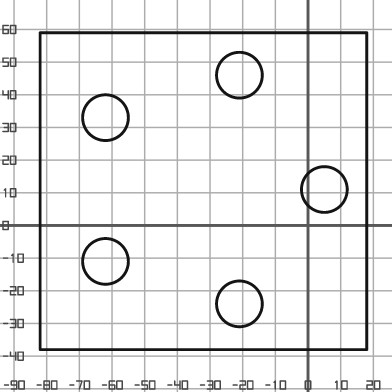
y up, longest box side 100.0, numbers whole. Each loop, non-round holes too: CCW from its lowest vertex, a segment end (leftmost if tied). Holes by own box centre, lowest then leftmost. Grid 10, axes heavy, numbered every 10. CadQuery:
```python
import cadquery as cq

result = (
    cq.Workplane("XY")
    .moveTo(-82.0, -38.0)
    .lineTo(18.0, -38.0)
    .lineTo(18.0, 59.0)
    .lineTo(-82.0, 59.0)
    .close()
    .moveTo(-21.0, -24.0)
    .circle(7.0)
    .moveTo(-62.0, -11.0)
    .circle(7.0)
    .moveTo(5.0, 11.0)
    .circle(7.0)
    .moveTo(-62.0, 33.0)
    .circle(7.0)
    .moveTo(-21.0, 46.0)
    .circle(7.0)
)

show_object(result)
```